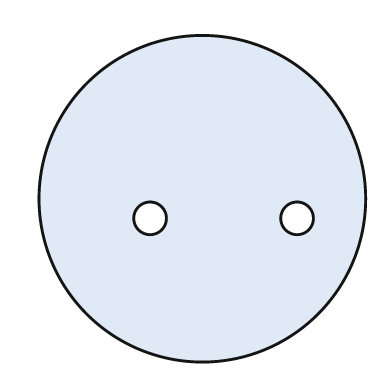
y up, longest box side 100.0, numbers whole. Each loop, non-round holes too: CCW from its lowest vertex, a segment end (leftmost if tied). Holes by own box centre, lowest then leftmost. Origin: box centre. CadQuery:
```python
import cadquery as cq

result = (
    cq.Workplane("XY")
    .moveTo(0.0, 0.0)
    .circle(50.0)
    .moveTo(-16.0, -6.0)
    .circle(5.0)
    .moveTo(29.0, -6.0)
    .circle(5.0)
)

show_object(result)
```